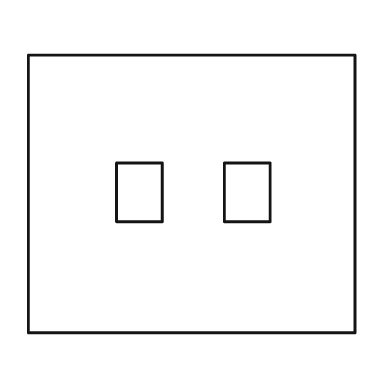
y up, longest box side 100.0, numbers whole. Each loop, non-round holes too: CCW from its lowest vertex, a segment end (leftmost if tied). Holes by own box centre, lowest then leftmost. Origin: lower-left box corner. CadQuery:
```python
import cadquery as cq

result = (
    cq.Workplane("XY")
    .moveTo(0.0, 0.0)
    .lineTo(100.0, 0.0)
    .lineTo(100.0, 85.0)
    .lineTo(0.0, 85.0)
    .close()
    .moveTo(27.0, 34.0)
    .lineTo(41.0, 34.0)
    .lineTo(41.0, 52.0)
    .lineTo(27.0, 52.0)
    .close()
    .moveTo(60.0, 34.0)
    .lineTo(74.0, 34.0)
    .lineTo(74.0, 52.0)
    .lineTo(60.0, 52.0)
    .close()
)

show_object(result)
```